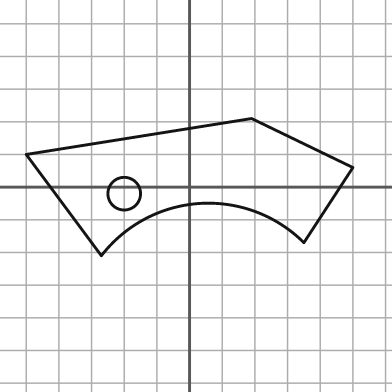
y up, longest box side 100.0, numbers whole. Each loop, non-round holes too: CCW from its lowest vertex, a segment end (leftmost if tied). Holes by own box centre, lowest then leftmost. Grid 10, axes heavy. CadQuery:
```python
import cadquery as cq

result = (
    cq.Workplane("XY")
    .moveTo(-27.0, -21.0)
    .threePointArc((3.0, -5.0), (35.0, -17.0))
    .lineTo(50.0, 6.0)
    .lineTo(19.0, 21.0)
    .lineTo(-50.0, 10.0)
    .close()
    .moveTo(-20.0, -2.0)
    .circle(5.0)
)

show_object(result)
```